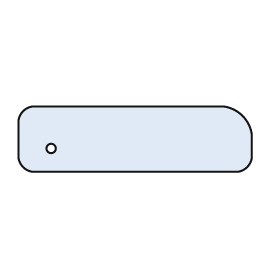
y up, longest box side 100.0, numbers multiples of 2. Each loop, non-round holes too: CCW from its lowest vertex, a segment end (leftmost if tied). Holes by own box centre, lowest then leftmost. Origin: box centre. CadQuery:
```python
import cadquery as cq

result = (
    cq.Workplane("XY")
    .moveTo(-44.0, -14.0)
    .lineTo(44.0, -14.0)
    .threePointArc((48.0, -12.0), (50.0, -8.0))
    .lineTo(50.0, 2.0)
    .threePointArc((46.0, 10.0), (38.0, 14.0))
    .lineTo(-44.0, 14.0)
    .threePointArc((-48.0, 12.0), (-50.0, 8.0))
    .lineTo(-50.0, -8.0)
    .threePointArc((-48.0, -12.0), (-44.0, -14.0))
    .close()
    .moveTo(-36.0, -4.0)
    .circle(2.0)
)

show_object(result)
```